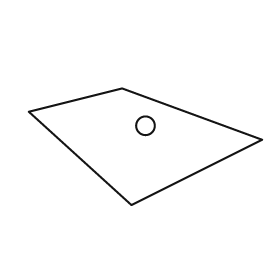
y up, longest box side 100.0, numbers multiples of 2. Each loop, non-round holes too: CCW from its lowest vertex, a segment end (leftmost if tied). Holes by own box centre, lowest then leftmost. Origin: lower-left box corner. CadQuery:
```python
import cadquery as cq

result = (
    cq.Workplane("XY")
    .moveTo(44.0, 0.0)
    .lineTo(100.0, 28.0)
    .lineTo(40.0, 50.0)
    .lineTo(0.0, 40.0)
    .close()
    .moveTo(50.0, 34.0)
    .circle(4.0)
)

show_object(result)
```